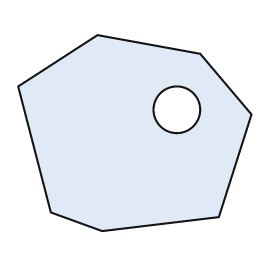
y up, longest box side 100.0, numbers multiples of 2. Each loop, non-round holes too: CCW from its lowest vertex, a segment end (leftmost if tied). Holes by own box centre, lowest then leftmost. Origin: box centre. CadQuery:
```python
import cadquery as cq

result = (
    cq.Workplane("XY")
    .moveTo(-14.0, -42.0)
    .lineTo(36.0, -36.0)
    .lineTo(50.0, 8.0)
    .lineTo(28.0, 34.0)
    .lineTo(-16.0, 42.0)
    .lineTo(-50.0, 20.0)
    .lineTo(-36.0, -34.0)
    .close()
    .moveTo(18.0, 10.0)
    .circle(10.0)
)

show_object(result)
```